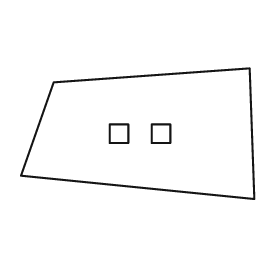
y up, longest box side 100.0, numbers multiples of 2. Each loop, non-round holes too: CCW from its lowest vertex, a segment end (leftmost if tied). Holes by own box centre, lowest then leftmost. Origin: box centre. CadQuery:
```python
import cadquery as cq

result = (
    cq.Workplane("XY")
    .moveTo(50.0, -28.0)
    .lineTo(48.0, 28.0)
    .lineTo(-36.0, 22.0)
    .lineTo(-50.0, -18.0)
    .close()
    .moveTo(-12.0, -4.0)
    .lineTo(-4.0, -4.0)
    .lineTo(-4.0, 4.0)
    .lineTo(-12.0, 4.0)
    .close()
    .moveTo(6.0, -4.0)
    .lineTo(14.0, -4.0)
    .lineTo(14.0, 4.0)
    .lineTo(6.0, 4.0)
    .close()
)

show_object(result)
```